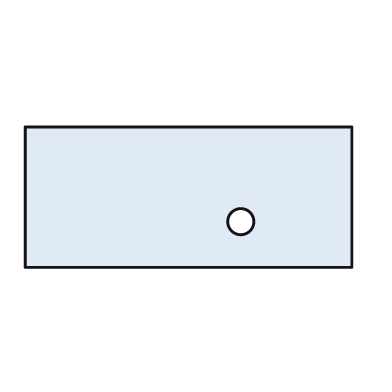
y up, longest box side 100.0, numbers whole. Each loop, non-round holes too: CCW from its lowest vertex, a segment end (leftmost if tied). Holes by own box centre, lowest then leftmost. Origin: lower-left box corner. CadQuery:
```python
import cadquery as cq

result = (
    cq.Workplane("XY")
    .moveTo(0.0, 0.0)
    .lineTo(100.0, 0.0)
    .lineTo(100.0, 43.0)
    .lineTo(0.0, 43.0)
    .close()
    .moveTo(66.0, 14.0)
    .circle(4.0)
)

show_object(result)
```